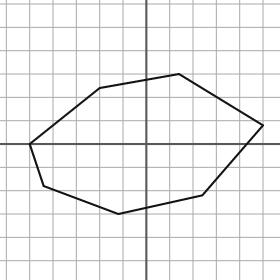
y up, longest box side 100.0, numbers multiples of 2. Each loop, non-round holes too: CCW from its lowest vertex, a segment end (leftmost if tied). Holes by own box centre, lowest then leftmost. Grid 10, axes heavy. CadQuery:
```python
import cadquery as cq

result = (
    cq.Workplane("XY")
    .moveTo(-12.0, -30.0)
    .lineTo(24.0, -22.0)
    .lineTo(50.0, 8.0)
    .lineTo(14.0, 30.0)
    .lineTo(-20.0, 24.0)
    .lineTo(-50.0, 0.0)
    .lineTo(-44.0, -18.0)
    .close()
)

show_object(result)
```